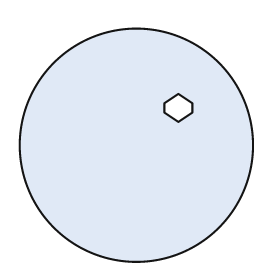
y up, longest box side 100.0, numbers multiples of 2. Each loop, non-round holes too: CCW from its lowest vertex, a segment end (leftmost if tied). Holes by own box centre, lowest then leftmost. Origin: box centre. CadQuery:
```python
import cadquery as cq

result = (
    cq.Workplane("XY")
    .moveTo(0.0, 0.0)
    .circle(50.0)
    .moveTo(18.0, 10.0)
    .lineTo(24.0, 14.0)
    .lineTo(24.0, 18.0)
    .lineTo(18.0, 22.0)
    .lineTo(12.0, 18.0)
    .lineTo(12.0, 14.0)
    .close()
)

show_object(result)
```